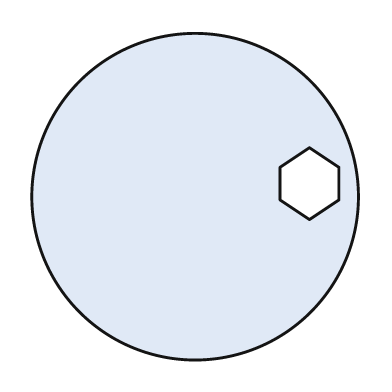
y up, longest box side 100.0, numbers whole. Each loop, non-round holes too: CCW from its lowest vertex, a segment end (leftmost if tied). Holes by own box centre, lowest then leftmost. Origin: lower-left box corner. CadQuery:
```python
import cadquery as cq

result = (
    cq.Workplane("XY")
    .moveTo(50.0, 50.0)
    .circle(50.0)
    .moveTo(85.0, 43.0)
    .lineTo(94.0, 49.0)
    .lineTo(94.0, 59.0)
    .lineTo(85.0, 65.0)
    .lineTo(76.0, 59.0)
    .lineTo(76.0, 49.0)
    .close()
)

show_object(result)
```